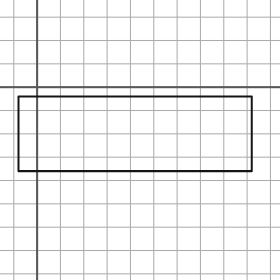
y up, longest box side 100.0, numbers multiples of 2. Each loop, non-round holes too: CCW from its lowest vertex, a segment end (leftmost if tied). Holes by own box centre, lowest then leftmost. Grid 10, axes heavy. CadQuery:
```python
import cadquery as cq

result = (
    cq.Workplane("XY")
    .moveTo(-8.0, -36.0)
    .lineTo(92.0, -36.0)
    .lineTo(92.0, -4.0)
    .lineTo(-8.0, -4.0)
    .close()
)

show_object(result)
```